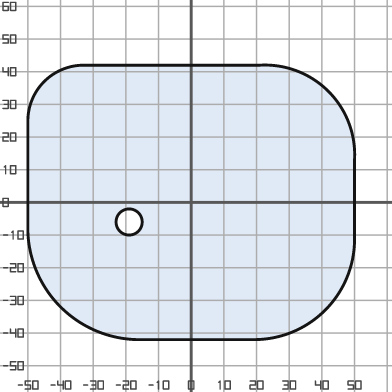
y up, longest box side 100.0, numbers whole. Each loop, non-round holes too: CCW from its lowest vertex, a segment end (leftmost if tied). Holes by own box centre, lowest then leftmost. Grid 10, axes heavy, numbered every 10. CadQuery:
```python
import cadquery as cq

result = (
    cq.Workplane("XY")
    .moveTo(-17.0, -42.0)
    .lineTo(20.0, -42.0)
    .threePointArc((41.0, -33.0), (50.0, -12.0))
    .lineTo(50.0, 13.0)
    .threePointArc((42.0, 34.0), (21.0, 42.0))
    .lineTo(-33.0, 42.0)
    .threePointArc((-45.0, 37.0), (-50.0, 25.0))
    .lineTo(-50.0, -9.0)
    .threePointArc((-40.0, -32.0), (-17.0, -42.0))
    .close()
    .moveTo(-19.0, -6.0)
    .circle(4.0)
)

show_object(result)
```